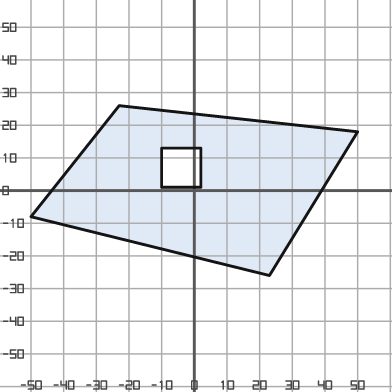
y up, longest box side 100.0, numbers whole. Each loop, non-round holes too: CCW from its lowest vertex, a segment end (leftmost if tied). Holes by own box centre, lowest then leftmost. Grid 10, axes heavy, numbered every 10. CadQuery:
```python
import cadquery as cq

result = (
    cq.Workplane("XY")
    .moveTo(23.0, -26.0)
    .lineTo(50.0, 18.0)
    .lineTo(-23.0, 26.0)
    .lineTo(-50.0, -8.0)
    .close()
    .moveTo(-10.0, 1.0)
    .lineTo(2.0, 1.0)
    .lineTo(2.0, 13.0)
    .lineTo(-10.0, 13.0)
    .close()
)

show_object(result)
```